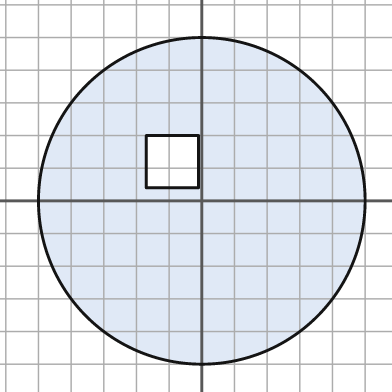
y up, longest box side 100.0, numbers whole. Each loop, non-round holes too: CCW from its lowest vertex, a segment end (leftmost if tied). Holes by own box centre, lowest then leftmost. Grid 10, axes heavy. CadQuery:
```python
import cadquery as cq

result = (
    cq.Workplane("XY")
    .moveTo(0.0, 0.0)
    .circle(50.0)
    .moveTo(-17.0, 4.0)
    .lineTo(-1.0, 4.0)
    .lineTo(-1.0, 20.0)
    .lineTo(-17.0, 20.0)
    .close()
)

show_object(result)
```